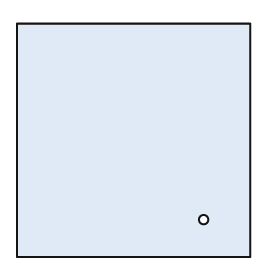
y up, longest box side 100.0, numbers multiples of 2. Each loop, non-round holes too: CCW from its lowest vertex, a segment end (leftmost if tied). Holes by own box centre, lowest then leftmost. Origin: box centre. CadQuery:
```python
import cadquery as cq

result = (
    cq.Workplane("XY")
    .moveTo(-50.0, -50.0)
    .lineTo(50.0, -50.0)
    .lineTo(50.0, 50.0)
    .lineTo(-50.0, 50.0)
    .close()
    .moveTo(30.0, -34.0)
    .circle(2.0)
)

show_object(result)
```